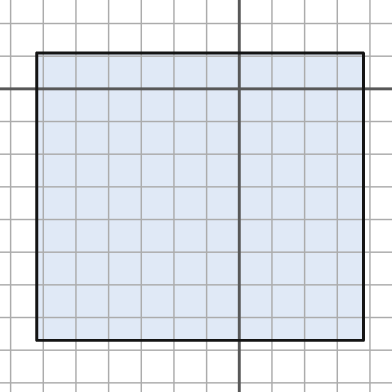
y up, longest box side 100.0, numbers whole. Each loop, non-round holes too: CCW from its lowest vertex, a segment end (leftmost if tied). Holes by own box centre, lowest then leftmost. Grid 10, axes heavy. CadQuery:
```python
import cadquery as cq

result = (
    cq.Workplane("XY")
    .moveTo(-62.0, -77.0)
    .lineTo(38.0, -77.0)
    .lineTo(38.0, 11.0)
    .lineTo(-62.0, 11.0)
    .close()
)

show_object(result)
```